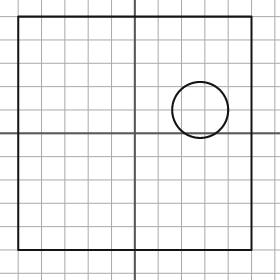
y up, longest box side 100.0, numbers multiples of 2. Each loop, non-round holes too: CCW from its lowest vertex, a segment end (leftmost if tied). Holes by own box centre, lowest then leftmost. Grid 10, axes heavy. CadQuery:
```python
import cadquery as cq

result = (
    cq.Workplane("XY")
    .moveTo(-50.0, -50.0)
    .lineTo(50.0, -50.0)
    .lineTo(50.0, 50.0)
    .lineTo(-50.0, 50.0)
    .close()
    .moveTo(28.0, 10.0)
    .circle(12.0)
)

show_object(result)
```